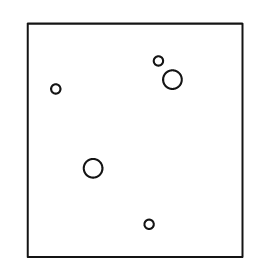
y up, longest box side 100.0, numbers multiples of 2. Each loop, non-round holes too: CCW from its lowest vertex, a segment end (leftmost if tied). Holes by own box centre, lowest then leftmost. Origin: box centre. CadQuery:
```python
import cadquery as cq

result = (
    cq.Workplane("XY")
    .moveTo(-46.0, -50.0)
    .lineTo(46.0, -50.0)
    .lineTo(46.0, 50.0)
    .lineTo(-46.0, 50.0)
    .close()
    .moveTo(6.0, -36.0)
    .circle(2.0)
    .moveTo(-18.0, -12.0)
    .circle(4.0)
    .moveTo(-34.0, 22.0)
    .circle(2.0)
    .moveTo(16.0, 26.0)
    .circle(4.0)
    .moveTo(10.0, 34.0)
    .circle(2.0)
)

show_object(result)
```